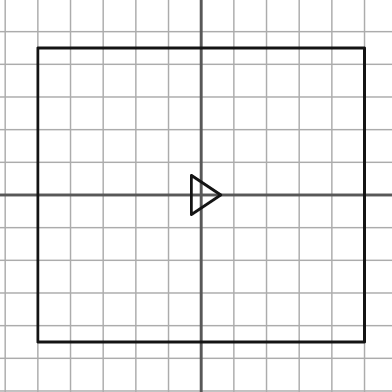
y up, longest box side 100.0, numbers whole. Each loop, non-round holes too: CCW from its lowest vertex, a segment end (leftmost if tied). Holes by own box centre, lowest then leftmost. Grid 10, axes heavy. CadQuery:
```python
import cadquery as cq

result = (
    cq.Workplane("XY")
    .moveTo(-50.0, -45.0)
    .lineTo(50.0, -45.0)
    .lineTo(50.0, 45.0)
    .lineTo(-50.0, 45.0)
    .close()
    .moveTo(-3.0, -6.0)
    .lineTo(6.0, 0.0)
    .lineTo(-3.0, 6.0)
    .close()
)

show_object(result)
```